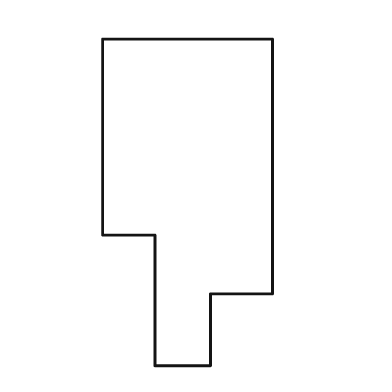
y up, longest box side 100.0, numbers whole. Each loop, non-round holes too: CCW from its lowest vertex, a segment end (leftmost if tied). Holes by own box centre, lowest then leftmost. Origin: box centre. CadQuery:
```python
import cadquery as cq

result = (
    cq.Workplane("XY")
    .moveTo(-10.0, -50.0)
    .lineTo(7.0, -50.0)
    .lineTo(7.0, -28.0)
    .lineTo(26.0, -28.0)
    .lineTo(26.0, 50.0)
    .lineTo(-26.0, 50.0)
    .lineTo(-26.0, -10.0)
    .lineTo(-10.0, -10.0)
    .close()
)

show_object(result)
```